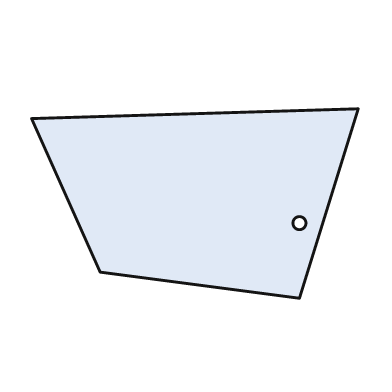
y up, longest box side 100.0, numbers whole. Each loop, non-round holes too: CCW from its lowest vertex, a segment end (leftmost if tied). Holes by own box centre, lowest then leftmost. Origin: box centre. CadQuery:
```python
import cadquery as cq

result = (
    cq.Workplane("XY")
    .moveTo(32.0, -29.0)
    .lineTo(50.0, 29.0)
    .lineTo(-50.0, 26.0)
    .lineTo(-29.0, -21.0)
    .close()
    .moveTo(32.0, -6.0)
    .circle(2.0)
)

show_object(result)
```